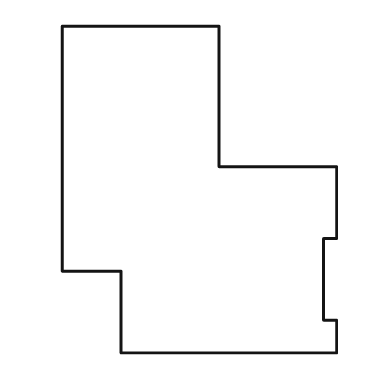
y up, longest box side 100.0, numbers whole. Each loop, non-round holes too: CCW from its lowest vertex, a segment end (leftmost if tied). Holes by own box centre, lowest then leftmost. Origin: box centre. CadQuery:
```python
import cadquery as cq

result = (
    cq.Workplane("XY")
    .moveTo(-24.0, -50.0)
    .lineTo(42.0, -50.0)
    .lineTo(42.0, -40.0)
    .lineTo(38.0, -40.0)
    .lineTo(38.0, -15.0)
    .lineTo(42.0, -15.0)
    .lineTo(42.0, 7.0)
    .lineTo(6.0, 7.0)
    .lineTo(6.0, 50.0)
    .lineTo(-42.0, 50.0)
    .lineTo(-42.0, -25.0)
    .lineTo(-24.0, -25.0)
    .close()
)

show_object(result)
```